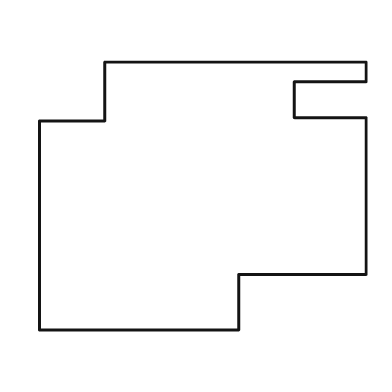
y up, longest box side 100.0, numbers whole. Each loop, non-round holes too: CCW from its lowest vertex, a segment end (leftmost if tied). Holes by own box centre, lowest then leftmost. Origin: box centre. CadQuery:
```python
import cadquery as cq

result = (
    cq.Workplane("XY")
    .moveTo(-50.0, -41.0)
    .lineTo(11.0, -41.0)
    .lineTo(11.0, -24.0)
    .lineTo(50.0, -24.0)
    .lineTo(50.0, 24.0)
    .lineTo(28.0, 24.0)
    .lineTo(28.0, 35.0)
    .lineTo(50.0, 35.0)
    .lineTo(50.0, 41.0)
    .lineTo(-30.0, 41.0)
    .lineTo(-30.0, 23.0)
    .lineTo(-50.0, 23.0)
    .close()
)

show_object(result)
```